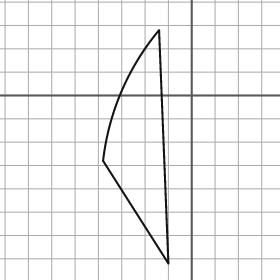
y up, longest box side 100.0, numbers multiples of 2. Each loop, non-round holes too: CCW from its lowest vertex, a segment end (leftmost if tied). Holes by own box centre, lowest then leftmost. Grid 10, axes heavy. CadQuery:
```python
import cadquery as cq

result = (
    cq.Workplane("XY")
    .moveTo(-10.0, -72.0)
    .lineTo(-14.0, 28.0)
    .threePointArc((-30.0, 2.0), (-38.0, -28.0))
    .close()
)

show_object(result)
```